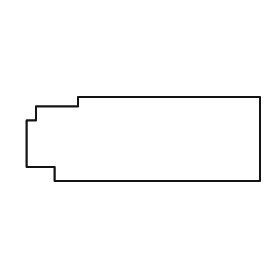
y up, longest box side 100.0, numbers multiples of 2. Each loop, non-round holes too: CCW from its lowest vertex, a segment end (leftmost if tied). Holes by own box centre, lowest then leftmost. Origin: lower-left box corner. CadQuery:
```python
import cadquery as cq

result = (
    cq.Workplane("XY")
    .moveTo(12.0, 0.0)
    .lineTo(100.0, 0.0)
    .lineTo(100.0, 36.0)
    .lineTo(22.0, 36.0)
    .lineTo(22.0, 32.0)
    .lineTo(4.0, 32.0)
    .lineTo(4.0, 26.0)
    .lineTo(0.0, 26.0)
    .lineTo(0.0, 6.0)
    .lineTo(12.0, 6.0)
    .close()
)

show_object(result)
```